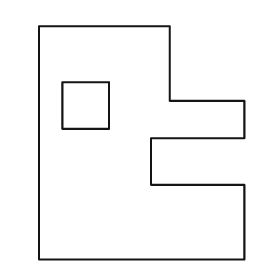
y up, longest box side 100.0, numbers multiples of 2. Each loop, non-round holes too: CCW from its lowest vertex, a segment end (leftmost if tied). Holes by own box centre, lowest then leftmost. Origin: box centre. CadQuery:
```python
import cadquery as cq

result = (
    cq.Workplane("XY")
    .moveTo(-44.0, -50.0)
    .lineTo(44.0, -50.0)
    .lineTo(44.0, -18.0)
    .lineTo(4.0, -18.0)
    .lineTo(4.0, 2.0)
    .lineTo(44.0, 2.0)
    .lineTo(44.0, 18.0)
    .lineTo(12.0, 18.0)
    .lineTo(12.0, 50.0)
    .lineTo(-44.0, 50.0)
    .close()
    .moveTo(-34.0, 6.0)
    .lineTo(-14.0, 6.0)
    .lineTo(-14.0, 26.0)
    .lineTo(-34.0, 26.0)
    .close()
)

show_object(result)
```